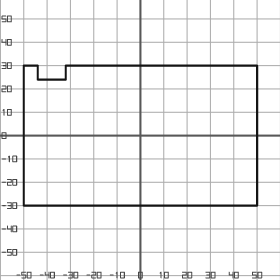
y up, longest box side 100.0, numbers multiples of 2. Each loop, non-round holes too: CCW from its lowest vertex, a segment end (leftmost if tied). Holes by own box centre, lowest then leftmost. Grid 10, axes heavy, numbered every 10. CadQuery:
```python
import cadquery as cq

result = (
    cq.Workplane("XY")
    .moveTo(-50.0, -30.0)
    .lineTo(50.0, -30.0)
    .lineTo(50.0, 30.0)
    .lineTo(-32.0, 30.0)
    .lineTo(-32.0, 24.0)
    .lineTo(-44.0, 24.0)
    .lineTo(-44.0, 30.0)
    .lineTo(-50.0, 30.0)
    .close()
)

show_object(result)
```